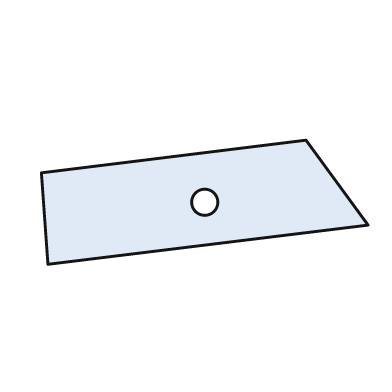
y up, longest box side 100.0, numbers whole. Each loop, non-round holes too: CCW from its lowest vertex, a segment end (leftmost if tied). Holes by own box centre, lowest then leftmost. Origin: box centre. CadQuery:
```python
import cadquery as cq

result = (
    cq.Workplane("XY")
    .moveTo(-48.0, -19.0)
    .lineTo(50.0, -7.0)
    .lineTo(31.0, 19.0)
    .lineTo(-50.0, 9.0)
    .close()
    .moveTo(0.0, 0.0)
    .circle(4.0)
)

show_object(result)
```